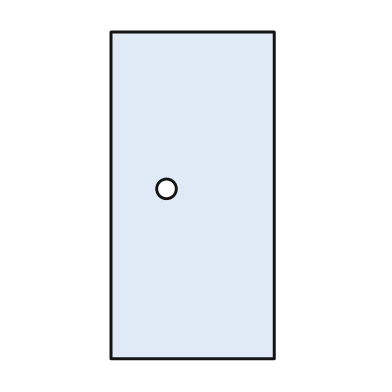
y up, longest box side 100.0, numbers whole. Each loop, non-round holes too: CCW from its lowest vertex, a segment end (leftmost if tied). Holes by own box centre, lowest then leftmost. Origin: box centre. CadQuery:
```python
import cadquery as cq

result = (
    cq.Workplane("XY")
    .moveTo(-25.0, -50.0)
    .lineTo(25.0, -50.0)
    .lineTo(25.0, 50.0)
    .lineTo(-25.0, 50.0)
    .close()
    .moveTo(-8.0, 2.0)
    .circle(3.0)
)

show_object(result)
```